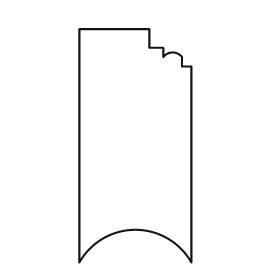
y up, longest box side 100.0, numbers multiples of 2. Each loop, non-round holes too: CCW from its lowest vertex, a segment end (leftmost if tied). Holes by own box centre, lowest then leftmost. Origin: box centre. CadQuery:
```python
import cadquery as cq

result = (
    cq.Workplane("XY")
    .moveTo(-24.0, -50.0)
    .threePointArc((0.0, -36.0), (24.0, -50.0))
    .lineTo(24.0, 34.0)
    .lineTo(20.0, 34.0)
    .lineTo(20.0, 38.0)
    .threePointArc((16.0, 40.0), (12.0, 38.0))
    .lineTo(12.0, 42.0)
    .lineTo(6.0, 42.0)
    .lineTo(6.0, 50.0)
    .lineTo(-24.0, 50.0)
    .close()
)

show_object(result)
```